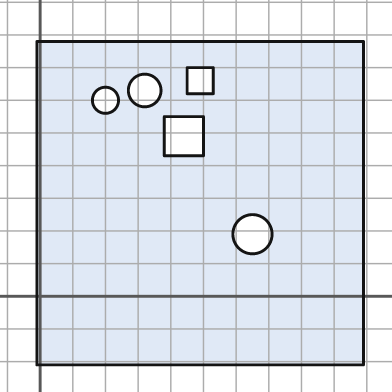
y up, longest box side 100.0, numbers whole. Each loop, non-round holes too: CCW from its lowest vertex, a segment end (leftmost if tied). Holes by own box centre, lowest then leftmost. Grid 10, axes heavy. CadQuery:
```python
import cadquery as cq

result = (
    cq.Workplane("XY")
    .moveTo(-1.0, -21.0)
    .lineTo(99.0, -21.0)
    .lineTo(99.0, 78.0)
    .lineTo(-1.0, 78.0)
    .close()
    .moveTo(65.0, 19.0)
    .circle(6.0)
    .moveTo(38.0, 43.0)
    .lineTo(50.0, 43.0)
    .lineTo(50.0, 55.0)
    .lineTo(38.0, 55.0)
    .close()
    .moveTo(20.0, 60.0)
    .circle(4.0)
    .moveTo(32.0, 63.0)
    .circle(5.0)
    .moveTo(45.0, 62.0)
    .lineTo(53.0, 62.0)
    .lineTo(53.0, 70.0)
    .lineTo(45.0, 70.0)
    .close()
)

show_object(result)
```